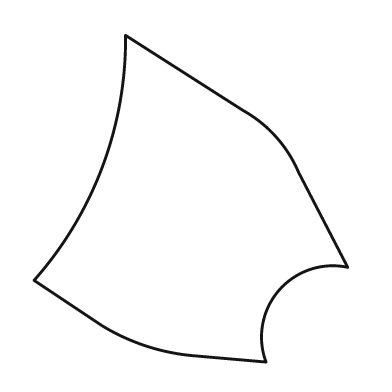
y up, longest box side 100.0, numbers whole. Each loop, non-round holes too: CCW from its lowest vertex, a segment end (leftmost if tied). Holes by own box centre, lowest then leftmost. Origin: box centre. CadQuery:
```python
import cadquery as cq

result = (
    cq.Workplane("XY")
    .moveTo(23.0, -50.0)
    .threePointArc((27.0, -28.0), (48.0, -21.0))
    .lineTo(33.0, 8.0)
    .threePointArc((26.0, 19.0), (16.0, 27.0))
    .lineTo(-20.0, 50.0)
    .threePointArc((-27.0, 10.0), (-48.0, -25.0))
    .lineTo(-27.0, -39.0)
    .threePointArc((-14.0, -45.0), (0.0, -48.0))
    .close()
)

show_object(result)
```